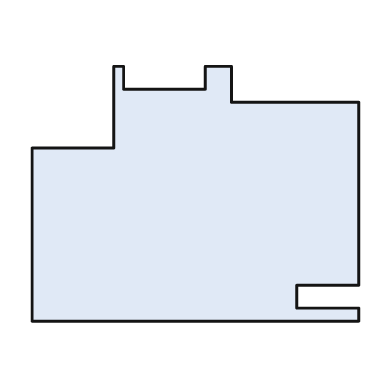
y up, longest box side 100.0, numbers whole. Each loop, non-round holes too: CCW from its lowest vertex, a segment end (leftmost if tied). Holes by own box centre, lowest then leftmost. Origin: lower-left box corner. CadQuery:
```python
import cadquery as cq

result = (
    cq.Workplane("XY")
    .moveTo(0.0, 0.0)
    .lineTo(100.0, 0.0)
    .lineTo(100.0, 4.0)
    .lineTo(81.0, 4.0)
    .lineTo(81.0, 11.0)
    .lineTo(100.0, 11.0)
    .lineTo(100.0, 67.0)
    .lineTo(61.0, 67.0)
    .lineTo(61.0, 78.0)
    .lineTo(53.0, 78.0)
    .lineTo(53.0, 71.0)
    .lineTo(28.0, 71.0)
    .lineTo(28.0, 78.0)
    .lineTo(25.0, 78.0)
    .lineTo(25.0, 53.0)
    .lineTo(0.0, 53.0)
    .close()
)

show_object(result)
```